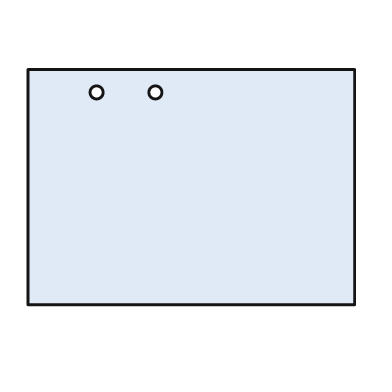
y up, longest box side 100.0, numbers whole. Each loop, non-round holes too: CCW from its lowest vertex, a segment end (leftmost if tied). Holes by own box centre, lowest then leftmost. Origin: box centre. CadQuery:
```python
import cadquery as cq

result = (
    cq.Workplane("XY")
    .moveTo(-50.0, -36.0)
    .lineTo(50.0, -36.0)
    .lineTo(50.0, 36.0)
    .lineTo(-50.0, 36.0)
    .close()
    .moveTo(-29.0, 29.0)
    .circle(2.0)
    .moveTo(-11.0, 29.0)
    .circle(2.0)
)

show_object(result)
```